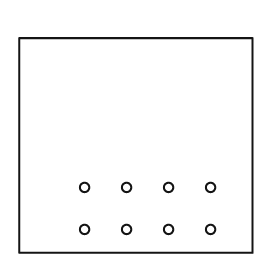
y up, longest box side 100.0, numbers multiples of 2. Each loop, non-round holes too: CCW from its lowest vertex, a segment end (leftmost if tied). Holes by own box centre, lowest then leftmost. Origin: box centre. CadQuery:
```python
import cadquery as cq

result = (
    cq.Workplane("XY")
    .moveTo(-50.0, -46.0)
    .lineTo(50.0, -46.0)
    .lineTo(50.0, 46.0)
    .lineTo(-50.0, 46.0)
    .close()
    .moveTo(-22.0, -36.0)
    .circle(2.0)
    .moveTo(-4.0, -36.0)
    .circle(2.0)
    .moveTo(14.0, -36.0)
    .circle(2.0)
    .moveTo(32.0, -36.0)
    .circle(2.0)
    .moveTo(-22.0, -18.0)
    .circle(2.0)
    .moveTo(-4.0, -18.0)
    .circle(2.0)
    .moveTo(14.0, -18.0)
    .circle(2.0)
    .moveTo(32.0, -18.0)
    .circle(2.0)
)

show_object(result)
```